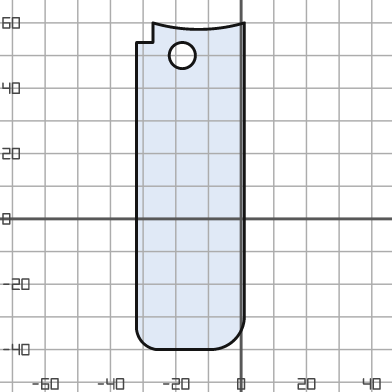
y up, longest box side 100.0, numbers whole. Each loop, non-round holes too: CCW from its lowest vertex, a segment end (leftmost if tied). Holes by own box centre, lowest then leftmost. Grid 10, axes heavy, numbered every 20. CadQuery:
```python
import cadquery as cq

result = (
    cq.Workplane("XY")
    .moveTo(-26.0, -40.0)
    .lineTo(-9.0, -40.0)
    .threePointArc((-2.0, -37.0), (1.0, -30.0))
    .lineTo(1.0, 60.0)
    .threePointArc((-13.0, 58.0), (-27.0, 60.0))
    .lineTo(-27.0, 54.0)
    .lineTo(-32.0, 54.0)
    .lineTo(-32.0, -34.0)
    .threePointArc((-30.0, -38.0), (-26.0, -40.0))
    .close()
    .moveTo(-18.0, 50.0)
    .circle(4.0)
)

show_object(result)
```